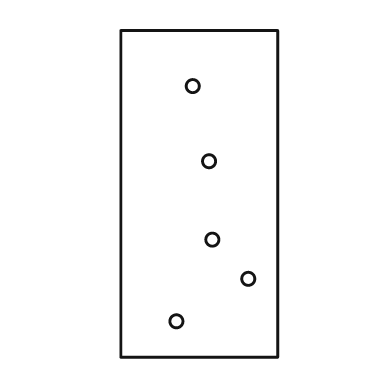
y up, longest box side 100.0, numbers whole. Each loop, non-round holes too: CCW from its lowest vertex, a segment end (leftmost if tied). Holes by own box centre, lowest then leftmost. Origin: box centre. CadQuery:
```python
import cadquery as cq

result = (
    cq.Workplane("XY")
    .moveTo(-24.0, -50.0)
    .lineTo(24.0, -50.0)
    .lineTo(24.0, 50.0)
    .lineTo(-24.0, 50.0)
    .close()
    .moveTo(-7.0, -39.0)
    .circle(2.0)
    .moveTo(15.0, -26.0)
    .circle(2.0)
    .moveTo(4.0, -14.0)
    .circle(2.0)
    .moveTo(3.0, 10.0)
    .circle(2.0)
    .moveTo(-2.0, 33.0)
    .circle(2.0)
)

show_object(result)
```